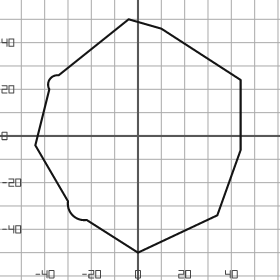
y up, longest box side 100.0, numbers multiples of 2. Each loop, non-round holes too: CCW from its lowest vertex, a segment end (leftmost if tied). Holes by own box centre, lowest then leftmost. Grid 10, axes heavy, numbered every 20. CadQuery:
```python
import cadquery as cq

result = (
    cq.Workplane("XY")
    .moveTo(0.0, -50.0)
    .lineTo(34.0, -34.0)
    .lineTo(44.0, -6.0)
    .lineTo(44.0, 24.0)
    .lineTo(10.0, 46.0)
    .lineTo(-4.0, 50.0)
    .lineTo(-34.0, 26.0)
    .threePointArc((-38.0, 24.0), (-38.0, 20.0))
    .lineTo(-44.0, -4.0)
    .lineTo(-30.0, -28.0)
    .threePointArc((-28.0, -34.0), (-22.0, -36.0))
    .close()
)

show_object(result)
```